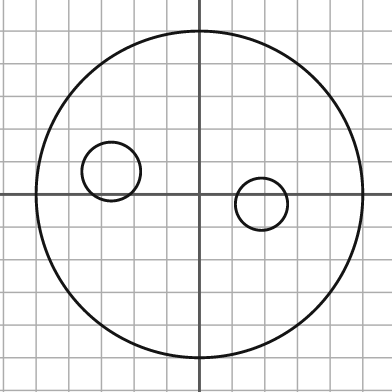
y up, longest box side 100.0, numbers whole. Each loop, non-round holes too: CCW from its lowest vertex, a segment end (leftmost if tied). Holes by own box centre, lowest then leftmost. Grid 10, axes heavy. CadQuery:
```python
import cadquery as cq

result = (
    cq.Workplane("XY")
    .moveTo(0.0, 0.0)
    .circle(50.0)
    .moveTo(19.0, -3.0)
    .circle(8.0)
    .moveTo(-27.0, 7.0)
    .circle(9.0)
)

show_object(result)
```